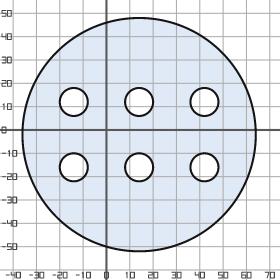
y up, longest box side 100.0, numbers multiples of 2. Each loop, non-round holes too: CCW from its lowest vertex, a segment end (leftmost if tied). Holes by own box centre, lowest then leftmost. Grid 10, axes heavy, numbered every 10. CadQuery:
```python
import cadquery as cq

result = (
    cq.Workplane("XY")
    .moveTo(14.0, -2.0)
    .circle(50.0)
    .moveTo(-14.0, -16.0)
    .circle(6.0)
    .moveTo(14.0, -16.0)
    .circle(6.0)
    .moveTo(42.0, -16.0)
    .circle(6.0)
    .moveTo(-14.0, 12.0)
    .circle(6.0)
    .moveTo(14.0, 12.0)
    .circle(6.0)
    .moveTo(42.0, 12.0)
    .circle(6.0)
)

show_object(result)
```